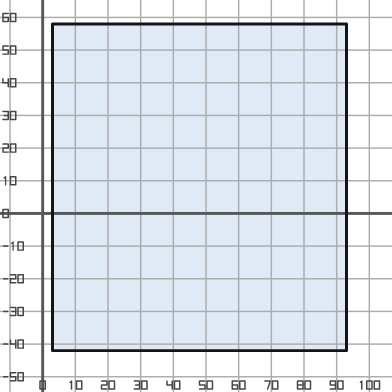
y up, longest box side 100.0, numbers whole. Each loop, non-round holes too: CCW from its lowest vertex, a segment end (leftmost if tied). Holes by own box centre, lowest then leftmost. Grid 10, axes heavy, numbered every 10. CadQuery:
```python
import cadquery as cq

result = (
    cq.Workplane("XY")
    .moveTo(3.0, -42.0)
    .lineTo(93.0, -42.0)
    .lineTo(93.0, 58.0)
    .lineTo(3.0, 58.0)
    .close()
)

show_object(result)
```